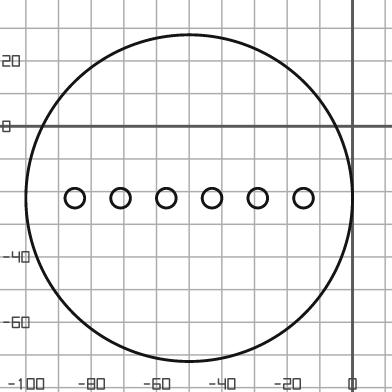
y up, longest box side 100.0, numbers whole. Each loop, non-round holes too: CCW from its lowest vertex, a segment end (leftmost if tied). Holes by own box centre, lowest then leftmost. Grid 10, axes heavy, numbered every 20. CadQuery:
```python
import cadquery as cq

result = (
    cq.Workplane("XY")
    .moveTo(-50.0, -22.0)
    .circle(50.0)
    .moveTo(-85.0, -22.0)
    .circle(3.0)
    .moveTo(-71.0, -22.0)
    .circle(3.0)
    .moveTo(-57.0, -22.0)
    .circle(3.0)
    .moveTo(-43.0, -22.0)
    .circle(3.0)
    .moveTo(-29.0, -22.0)
    .circle(3.0)
    .moveTo(-15.0, -22.0)
    .circle(3.0)
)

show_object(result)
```